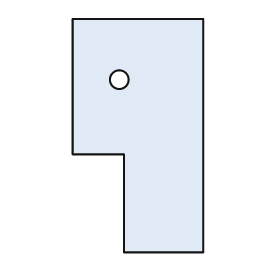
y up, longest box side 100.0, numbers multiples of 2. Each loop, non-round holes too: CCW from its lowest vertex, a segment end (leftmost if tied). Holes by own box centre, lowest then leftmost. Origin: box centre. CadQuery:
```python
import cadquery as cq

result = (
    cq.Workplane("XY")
    .moveTo(-6.0, -50.0)
    .lineTo(28.0, -50.0)
    .lineTo(28.0, 50.0)
    .lineTo(-28.0, 50.0)
    .lineTo(-28.0, -8.0)
    .lineTo(-6.0, -8.0)
    .close()
    .moveTo(-8.0, 24.0)
    .circle(4.0)
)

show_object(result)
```